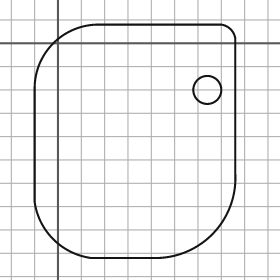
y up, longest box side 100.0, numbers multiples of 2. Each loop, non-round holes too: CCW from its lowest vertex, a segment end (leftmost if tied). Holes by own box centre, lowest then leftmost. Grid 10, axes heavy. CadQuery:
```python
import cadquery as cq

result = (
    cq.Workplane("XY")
    .moveTo(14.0, -92.0)
    .lineTo(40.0, -92.0)
    .threePointArc((66.0, -82.0), (76.0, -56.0))
    .lineTo(76.0, 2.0)
    .threePointArc((74.0, 6.0), (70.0, 8.0))
    .lineTo(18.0, 8.0)
    .threePointArc((-2.0, 0.0), (-10.0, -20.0))
    .lineTo(-10.0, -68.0)
    .threePointArc((-2.0, -84.0), (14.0, -92.0))
    .close()
    .moveTo(64.0, -20.0)
    .circle(6.0)
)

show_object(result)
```